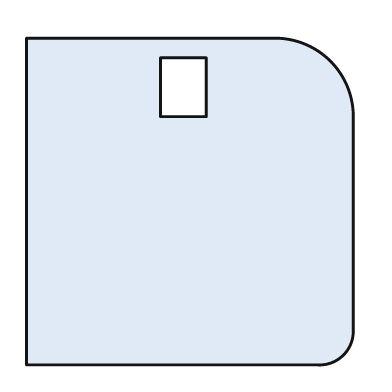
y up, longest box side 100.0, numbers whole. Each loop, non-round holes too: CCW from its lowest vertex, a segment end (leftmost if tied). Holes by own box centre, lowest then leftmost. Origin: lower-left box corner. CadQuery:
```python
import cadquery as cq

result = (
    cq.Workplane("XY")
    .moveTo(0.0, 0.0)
    .lineTo(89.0, 0.0)
    .threePointArc((97.0, 3.0), (100.0, 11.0))
    .lineTo(100.0, 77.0)
    .threePointArc((93.0, 93.0), (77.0, 100.0))
    .lineTo(0.0, 100.0)
    .close()
    .moveTo(41.0, 76.0)
    .lineTo(55.0, 76.0)
    .lineTo(55.0, 94.0)
    .lineTo(41.0, 94.0)
    .close()
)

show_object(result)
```